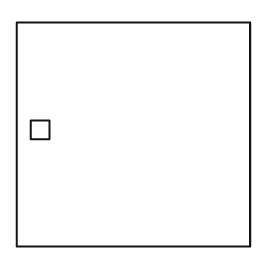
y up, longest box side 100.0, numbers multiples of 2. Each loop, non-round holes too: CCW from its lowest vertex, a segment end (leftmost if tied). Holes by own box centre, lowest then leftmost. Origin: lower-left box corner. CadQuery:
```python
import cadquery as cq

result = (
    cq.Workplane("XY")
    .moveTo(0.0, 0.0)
    .lineTo(100.0, 0.0)
    .lineTo(100.0, 96.0)
    .lineTo(0.0, 96.0)
    .close()
    .moveTo(6.0, 46.0)
    .lineTo(14.0, 46.0)
    .lineTo(14.0, 54.0)
    .lineTo(6.0, 54.0)
    .close()
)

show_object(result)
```